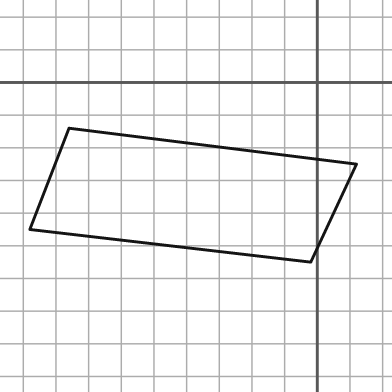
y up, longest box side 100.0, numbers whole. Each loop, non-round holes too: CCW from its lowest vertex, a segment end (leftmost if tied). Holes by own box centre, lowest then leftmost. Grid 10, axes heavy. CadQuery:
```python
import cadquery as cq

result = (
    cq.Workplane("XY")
    .moveTo(-2.0, -55.0)
    .lineTo(12.0, -25.0)
    .lineTo(-76.0, -14.0)
    .lineTo(-88.0, -45.0)
    .close()
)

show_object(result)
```